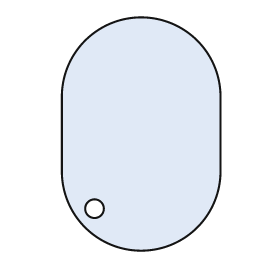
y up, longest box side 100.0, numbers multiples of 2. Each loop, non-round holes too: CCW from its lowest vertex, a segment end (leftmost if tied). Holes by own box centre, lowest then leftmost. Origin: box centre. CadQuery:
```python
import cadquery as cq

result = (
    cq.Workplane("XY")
    .moveTo(-34.0, -16.0)
    .threePointArc((0.0, -50.0), (34.0, -16.0))
    .lineTo(34.0, 16.0)
    .threePointArc((0.0, 50.0), (-34.0, 16.0))
    .close()
    .moveTo(-20.0, -32.0)
    .circle(4.0)
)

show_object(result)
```